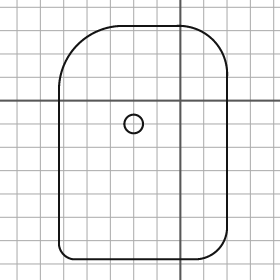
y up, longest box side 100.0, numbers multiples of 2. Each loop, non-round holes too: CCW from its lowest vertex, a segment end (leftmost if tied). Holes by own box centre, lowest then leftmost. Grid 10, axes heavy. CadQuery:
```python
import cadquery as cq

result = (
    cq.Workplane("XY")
    .moveTo(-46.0, -68.0)
    .lineTo(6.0, -68.0)
    .threePointArc((16.0, -64.0), (20.0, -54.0))
    .lineTo(20.0, 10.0)
    .threePointArc((14.0, 26.0), (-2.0, 32.0))
    .lineTo(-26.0, 32.0)
    .threePointArc((-44.0, 24.0), (-52.0, 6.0))
    .lineTo(-52.0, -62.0)
    .threePointArc((-50.0, -66.0), (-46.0, -68.0))
    .close()
    .moveTo(-20.0, -10.0)
    .circle(4.0)
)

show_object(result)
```